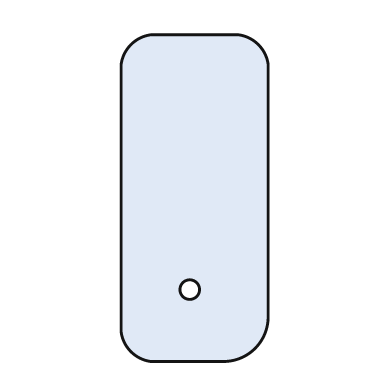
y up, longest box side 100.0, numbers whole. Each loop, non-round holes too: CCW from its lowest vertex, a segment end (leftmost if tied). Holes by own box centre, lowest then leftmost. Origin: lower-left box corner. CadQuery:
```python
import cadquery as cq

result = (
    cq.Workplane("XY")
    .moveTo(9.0, 0.0)
    .lineTo(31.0, 0.0)
    .threePointArc((41.0, 4.0), (45.0, 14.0))
    .lineTo(45.0, 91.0)
    .threePointArc((42.0, 97.0), (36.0, 100.0))
    .lineTo(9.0, 100.0)
    .threePointArc((3.0, 97.0), (0.0, 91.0))
    .lineTo(0.0, 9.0)
    .threePointArc((3.0, 3.0), (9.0, 0.0))
    .close()
    .moveTo(21.0, 22.0)
    .circle(3.0)
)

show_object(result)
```